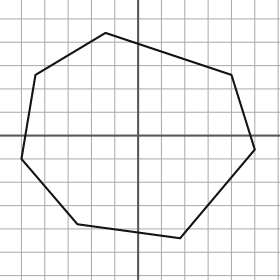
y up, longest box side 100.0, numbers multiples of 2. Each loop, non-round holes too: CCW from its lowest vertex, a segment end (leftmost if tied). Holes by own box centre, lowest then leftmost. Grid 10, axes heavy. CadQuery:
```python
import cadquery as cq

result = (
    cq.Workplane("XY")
    .moveTo(18.0, -44.0)
    .lineTo(50.0, -6.0)
    .lineTo(40.0, 26.0)
    .lineTo(-14.0, 44.0)
    .lineTo(-44.0, 26.0)
    .lineTo(-50.0, -10.0)
    .lineTo(-26.0, -38.0)
    .close()
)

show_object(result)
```